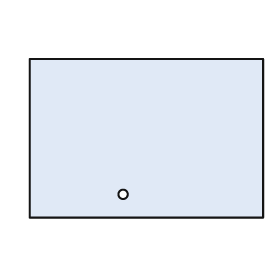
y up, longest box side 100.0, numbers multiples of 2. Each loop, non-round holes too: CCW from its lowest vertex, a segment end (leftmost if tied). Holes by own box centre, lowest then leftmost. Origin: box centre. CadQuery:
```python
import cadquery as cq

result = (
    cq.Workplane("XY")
    .moveTo(-50.0, -34.0)
    .lineTo(50.0, -34.0)
    .lineTo(50.0, 34.0)
    .lineTo(-50.0, 34.0)
    .close()
    .moveTo(-10.0, -24.0)
    .circle(2.0)
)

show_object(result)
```